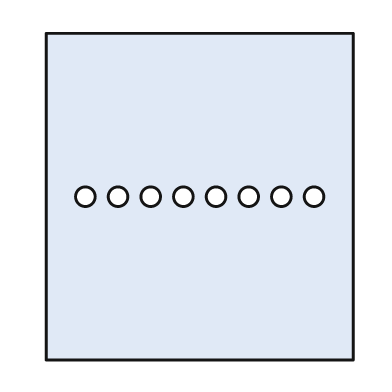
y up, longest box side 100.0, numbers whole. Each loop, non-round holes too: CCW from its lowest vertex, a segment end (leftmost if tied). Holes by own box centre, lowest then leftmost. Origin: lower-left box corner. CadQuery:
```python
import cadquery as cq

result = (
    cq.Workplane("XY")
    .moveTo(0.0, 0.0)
    .lineTo(94.0, 0.0)
    .lineTo(94.0, 100.0)
    .lineTo(0.0, 100.0)
    .close()
    .moveTo(12.0, 50.0)
    .circle(3.0)
    .moveTo(22.0, 50.0)
    .circle(3.0)
    .moveTo(32.0, 50.0)
    .circle(3.0)
    .moveTo(42.0, 50.0)
    .circle(3.0)
    .moveTo(52.0, 50.0)
    .circle(3.0)
    .moveTo(62.0, 50.0)
    .circle(3.0)
    .moveTo(72.0, 50.0)
    .circle(3.0)
    .moveTo(82.0, 50.0)
    .circle(3.0)
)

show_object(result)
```